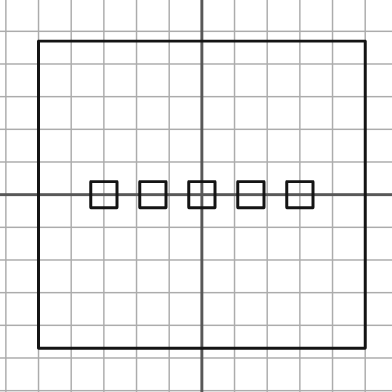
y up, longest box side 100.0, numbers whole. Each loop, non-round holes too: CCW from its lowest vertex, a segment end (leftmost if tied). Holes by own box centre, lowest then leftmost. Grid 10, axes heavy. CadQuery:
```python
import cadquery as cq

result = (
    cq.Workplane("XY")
    .moveTo(-50.0, -47.0)
    .lineTo(50.0, -47.0)
    .lineTo(50.0, 47.0)
    .lineTo(-50.0, 47.0)
    .close()
    .moveTo(-34.0, -4.0)
    .lineTo(-26.0, -4.0)
    .lineTo(-26.0, 4.0)
    .lineTo(-34.0, 4.0)
    .close()
    .moveTo(-19.0, -4.0)
    .lineTo(-11.0, -4.0)
    .lineTo(-11.0, 4.0)
    .lineTo(-19.0, 4.0)
    .close()
    .moveTo(-4.0, -4.0)
    .lineTo(4.0, -4.0)
    .lineTo(4.0, 4.0)
    .lineTo(-4.0, 4.0)
    .close()
    .moveTo(11.0, -4.0)
    .lineTo(19.0, -4.0)
    .lineTo(19.0, 4.0)
    .lineTo(11.0, 4.0)
    .close()
    .moveTo(26.0, -4.0)
    .lineTo(34.0, -4.0)
    .lineTo(34.0, 4.0)
    .lineTo(26.0, 4.0)
    .close()
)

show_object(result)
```